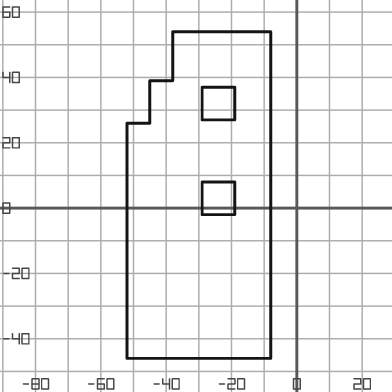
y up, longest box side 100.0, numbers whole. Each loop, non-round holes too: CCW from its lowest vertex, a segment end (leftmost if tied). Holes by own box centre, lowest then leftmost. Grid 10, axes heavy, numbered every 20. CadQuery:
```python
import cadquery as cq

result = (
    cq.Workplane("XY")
    .moveTo(-52.0, -46.0)
    .lineTo(-8.0, -46.0)
    .lineTo(-8.0, 54.0)
    .lineTo(-38.0, 54.0)
    .lineTo(-38.0, 39.0)
    .lineTo(-45.0, 39.0)
    .lineTo(-45.0, 26.0)
    .lineTo(-52.0, 26.0)
    .close()
    .moveTo(-29.0, -2.0)
    .lineTo(-19.0, -2.0)
    .lineTo(-19.0, 8.0)
    .lineTo(-29.0, 8.0)
    .close()
    .moveTo(-29.0, 27.0)
    .lineTo(-19.0, 27.0)
    .lineTo(-19.0, 37.0)
    .lineTo(-29.0, 37.0)
    .close()
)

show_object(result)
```